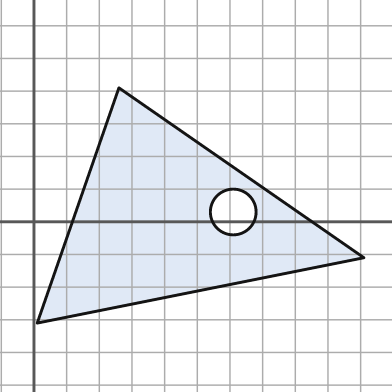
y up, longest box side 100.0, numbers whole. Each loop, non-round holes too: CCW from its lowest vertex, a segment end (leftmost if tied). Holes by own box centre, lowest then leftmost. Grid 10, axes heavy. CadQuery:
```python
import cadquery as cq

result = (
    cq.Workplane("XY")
    .moveTo(1.0, -31.0)
    .lineTo(101.0, -11.0)
    .lineTo(26.0, 41.0)
    .close()
    .moveTo(61.0, 3.0)
    .circle(7.0)
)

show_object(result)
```